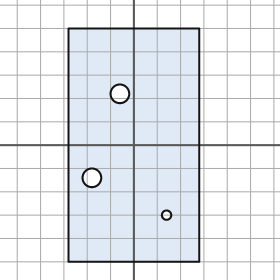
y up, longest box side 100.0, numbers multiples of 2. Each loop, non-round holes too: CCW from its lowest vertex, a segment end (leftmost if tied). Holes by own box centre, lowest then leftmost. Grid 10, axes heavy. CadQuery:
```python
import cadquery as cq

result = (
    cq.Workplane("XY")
    .moveTo(-28.0, -50.0)
    .lineTo(28.0, -50.0)
    .lineTo(28.0, 50.0)
    .lineTo(-28.0, 50.0)
    .close()
    .moveTo(14.0, -30.0)
    .circle(2.0)
    .moveTo(-18.0, -14.0)
    .circle(4.0)
    .moveTo(-6.0, 22.0)
    .circle(4.0)
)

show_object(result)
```